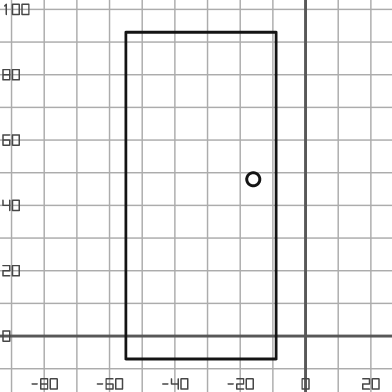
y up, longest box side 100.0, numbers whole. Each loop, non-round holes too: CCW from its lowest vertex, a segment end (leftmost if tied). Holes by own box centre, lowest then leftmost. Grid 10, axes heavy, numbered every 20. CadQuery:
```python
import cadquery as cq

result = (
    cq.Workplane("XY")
    .moveTo(-55.0, -7.0)
    .lineTo(-9.0, -7.0)
    .lineTo(-9.0, 93.0)
    .lineTo(-55.0, 93.0)
    .close()
    .moveTo(-16.0, 48.0)
    .circle(2.0)
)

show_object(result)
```